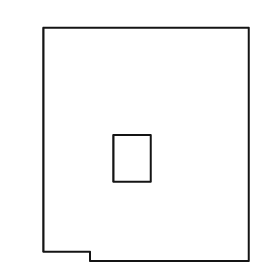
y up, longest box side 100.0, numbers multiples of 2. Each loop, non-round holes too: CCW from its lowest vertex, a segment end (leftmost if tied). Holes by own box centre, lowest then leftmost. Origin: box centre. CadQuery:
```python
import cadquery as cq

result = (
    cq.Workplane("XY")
    .moveTo(-24.0, -50.0)
    .lineTo(44.0, -50.0)
    .lineTo(44.0, 50.0)
    .lineTo(-44.0, 50.0)
    .lineTo(-44.0, -46.0)
    .lineTo(-24.0, -46.0)
    .close()
    .moveTo(-14.0, -16.0)
    .lineTo(2.0, -16.0)
    .lineTo(2.0, 4.0)
    .lineTo(-14.0, 4.0)
    .close()
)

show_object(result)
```